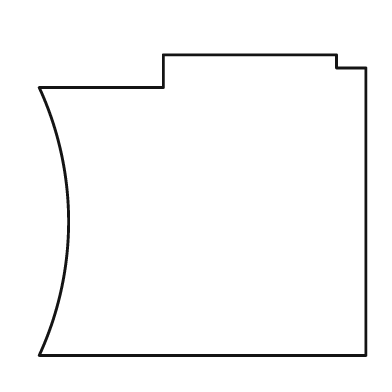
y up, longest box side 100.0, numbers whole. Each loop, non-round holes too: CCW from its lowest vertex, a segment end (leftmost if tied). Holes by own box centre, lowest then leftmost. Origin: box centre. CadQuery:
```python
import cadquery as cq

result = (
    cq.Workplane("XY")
    .moveTo(-50.0, -46.0)
    .lineTo(50.0, -46.0)
    .lineTo(50.0, 42.0)
    .lineTo(41.0, 42.0)
    .lineTo(41.0, 46.0)
    .lineTo(-12.0, 46.0)
    .lineTo(-12.0, 36.0)
    .lineTo(-50.0, 36.0)
    .threePointArc((-41.0, -5.0), (-50.0, -46.0))
    .close()
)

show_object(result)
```